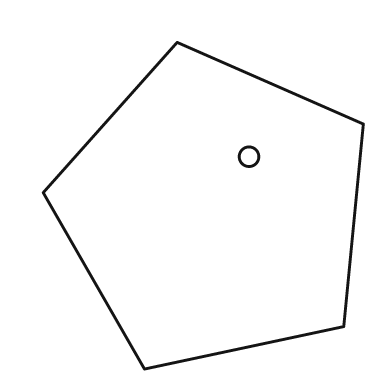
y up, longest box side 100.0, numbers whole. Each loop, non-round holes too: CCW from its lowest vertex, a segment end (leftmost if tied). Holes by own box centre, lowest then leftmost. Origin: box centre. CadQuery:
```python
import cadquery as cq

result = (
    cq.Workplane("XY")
    .moveTo(-18.0, -50.0)
    .lineTo(43.0, -37.0)
    .lineTo(49.0, 25.0)
    .lineTo(-8.0, 50.0)
    .lineTo(-49.0, 4.0)
    .close()
    .moveTo(14.0, 15.0)
    .circle(3.0)
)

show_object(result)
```